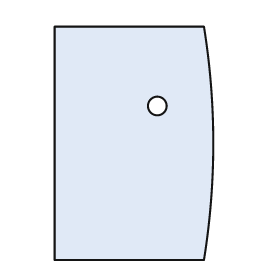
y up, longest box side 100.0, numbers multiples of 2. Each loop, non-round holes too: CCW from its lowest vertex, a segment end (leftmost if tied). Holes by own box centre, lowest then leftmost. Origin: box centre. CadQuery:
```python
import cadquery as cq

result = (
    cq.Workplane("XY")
    .moveTo(-34.0, -50.0)
    .lineTo(30.0, -50.0)
    .threePointArc((34.0, 0.0), (30.0, 50.0))
    .lineTo(-34.0, 50.0)
    .close()
    .moveTo(10.0, 16.0)
    .circle(4.0)
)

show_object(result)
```